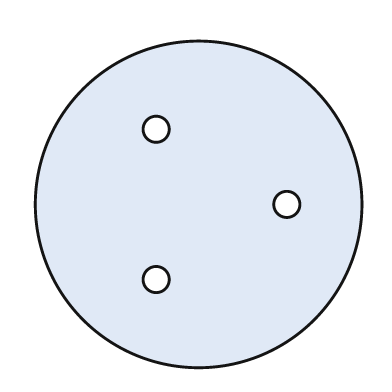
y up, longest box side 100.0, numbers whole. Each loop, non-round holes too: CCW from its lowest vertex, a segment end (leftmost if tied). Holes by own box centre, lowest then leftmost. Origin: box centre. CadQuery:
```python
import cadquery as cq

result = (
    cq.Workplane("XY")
    .moveTo(0.0, 0.0)
    .circle(50.0)
    .moveTo(-13.0, -23.0)
    .circle(4.0)
    .moveTo(27.0, 0.0)
    .circle(4.0)
    .moveTo(-13.0, 23.0)
    .circle(4.0)
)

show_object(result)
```